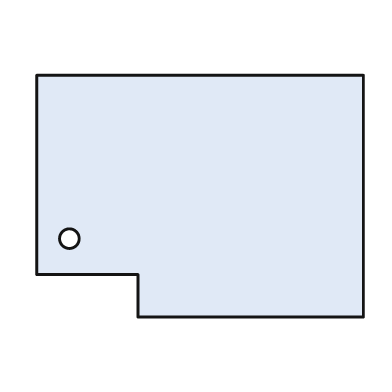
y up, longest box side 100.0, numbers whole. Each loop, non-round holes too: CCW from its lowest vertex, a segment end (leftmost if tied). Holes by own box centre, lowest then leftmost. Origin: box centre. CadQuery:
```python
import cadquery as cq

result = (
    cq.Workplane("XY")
    .moveTo(-19.0, -37.0)
    .lineTo(50.0, -37.0)
    .lineTo(50.0, 37.0)
    .lineTo(-50.0, 37.0)
    .lineTo(-50.0, -24.0)
    .lineTo(-19.0, -24.0)
    .close()
    .moveTo(-40.0, -13.0)
    .circle(3.0)
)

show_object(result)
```